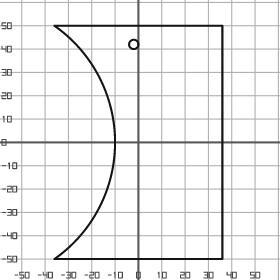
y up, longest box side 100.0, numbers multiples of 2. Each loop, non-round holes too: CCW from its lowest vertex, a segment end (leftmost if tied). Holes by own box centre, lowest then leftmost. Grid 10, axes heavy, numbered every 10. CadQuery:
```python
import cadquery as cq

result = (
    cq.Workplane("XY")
    .moveTo(-36.0, -50.0)
    .lineTo(36.0, -50.0)
    .lineTo(36.0, 50.0)
    .lineTo(-36.0, 50.0)
    .threePointArc((-10.0, 0.0), (-36.0, -50.0))
    .close()
    .moveTo(-2.0, 42.0)
    .circle(2.0)
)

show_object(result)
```